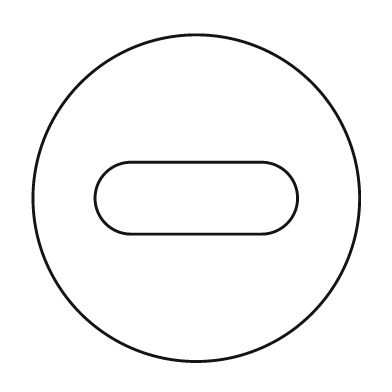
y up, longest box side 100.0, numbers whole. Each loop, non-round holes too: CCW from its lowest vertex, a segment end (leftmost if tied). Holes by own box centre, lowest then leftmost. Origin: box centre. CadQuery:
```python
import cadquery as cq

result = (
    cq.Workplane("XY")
    .moveTo(0.0, 0.0)
    .circle(50.0)
    .moveTo(-20.0, -11.0)
    .lineTo(20.0, -11.0)
    .threePointArc((31.0, 0.0), (20.0, 11.0))
    .lineTo(-20.0, 11.0)
    .threePointArc((-31.0, 0.0), (-20.0, -11.0))
    .close()
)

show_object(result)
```